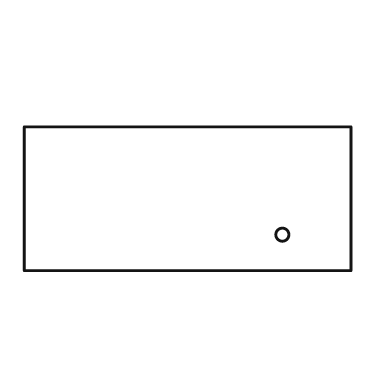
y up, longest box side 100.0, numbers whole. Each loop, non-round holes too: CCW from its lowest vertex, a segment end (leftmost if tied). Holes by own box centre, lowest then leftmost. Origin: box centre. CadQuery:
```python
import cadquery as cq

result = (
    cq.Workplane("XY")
    .moveTo(-50.0, -22.0)
    .lineTo(50.0, -22.0)
    .lineTo(50.0, 22.0)
    .lineTo(-50.0, 22.0)
    .close()
    .moveTo(29.0, -11.0)
    .circle(2.0)
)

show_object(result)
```